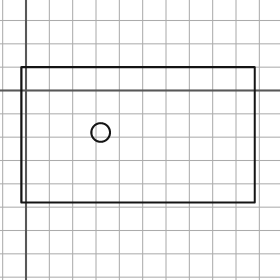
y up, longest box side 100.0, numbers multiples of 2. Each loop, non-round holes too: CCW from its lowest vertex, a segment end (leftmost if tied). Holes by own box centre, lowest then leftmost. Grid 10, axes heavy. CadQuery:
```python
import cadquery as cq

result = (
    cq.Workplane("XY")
    .moveTo(-2.0, -48.0)
    .lineTo(98.0, -48.0)
    .lineTo(98.0, 10.0)
    .lineTo(-2.0, 10.0)
    .close()
    .moveTo(32.0, -18.0)
    .circle(4.0)
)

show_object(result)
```